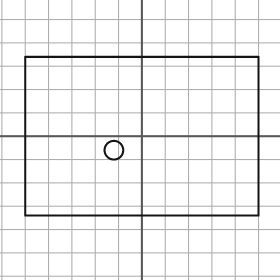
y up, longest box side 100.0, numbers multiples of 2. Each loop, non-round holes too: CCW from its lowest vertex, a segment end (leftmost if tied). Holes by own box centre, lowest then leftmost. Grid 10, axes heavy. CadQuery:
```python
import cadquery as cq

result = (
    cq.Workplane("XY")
    .moveTo(-50.0, -34.0)
    .lineTo(50.0, -34.0)
    .lineTo(50.0, 34.0)
    .lineTo(-50.0, 34.0)
    .close()
    .moveTo(-12.0, -6.0)
    .circle(4.0)
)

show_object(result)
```